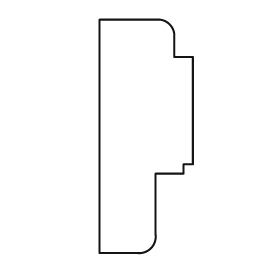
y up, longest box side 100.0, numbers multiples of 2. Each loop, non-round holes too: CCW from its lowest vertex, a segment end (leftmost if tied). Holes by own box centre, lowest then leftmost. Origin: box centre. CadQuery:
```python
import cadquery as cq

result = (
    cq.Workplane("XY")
    .moveTo(-20.0, -50.0)
    .lineTo(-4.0, -50.0)
    .threePointArc((2.0, -48.0), (4.0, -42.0))
    .lineTo(4.0, -16.0)
    .lineTo(16.0, -16.0)
    .lineTo(16.0, -12.0)
    .lineTo(20.0, -12.0)
    .lineTo(20.0, 34.0)
    .lineTo(12.0, 34.0)
    .lineTo(12.0, 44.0)
    .threePointArc((10.0, 48.0), (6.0, 50.0))
    .lineTo(-20.0, 50.0)
    .close()
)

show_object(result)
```